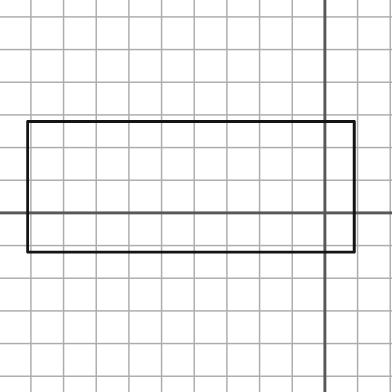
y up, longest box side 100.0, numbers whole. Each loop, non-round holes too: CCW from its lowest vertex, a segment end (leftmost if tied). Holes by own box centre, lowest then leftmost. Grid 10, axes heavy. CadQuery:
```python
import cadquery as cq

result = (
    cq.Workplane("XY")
    .moveTo(-91.0, -12.0)
    .lineTo(9.0, -12.0)
    .lineTo(9.0, 28.0)
    .lineTo(-91.0, 28.0)
    .close()
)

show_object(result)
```